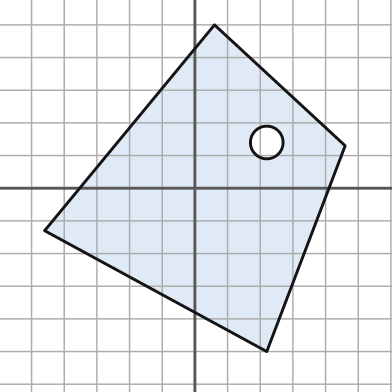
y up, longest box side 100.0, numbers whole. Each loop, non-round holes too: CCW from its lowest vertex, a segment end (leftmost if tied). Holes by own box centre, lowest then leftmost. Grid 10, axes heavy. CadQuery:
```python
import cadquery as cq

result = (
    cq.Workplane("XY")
    .moveTo(22.0, -50.0)
    .lineTo(46.0, 13.0)
    .lineTo(6.0, 50.0)
    .lineTo(-46.0, -13.0)
    .close()
    .moveTo(22.0, 14.0)
    .circle(5.0)
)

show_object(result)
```